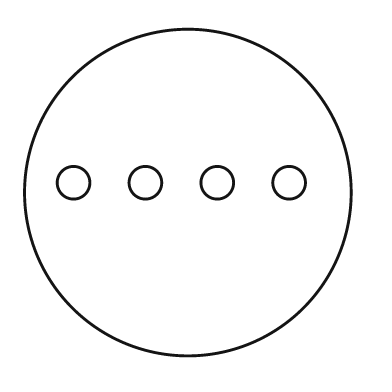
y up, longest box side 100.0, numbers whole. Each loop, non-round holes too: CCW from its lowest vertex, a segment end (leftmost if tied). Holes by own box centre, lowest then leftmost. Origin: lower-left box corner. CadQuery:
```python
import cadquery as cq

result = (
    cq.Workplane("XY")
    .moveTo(50.0, 50.0)
    .circle(50.0)
    .moveTo(15.0, 53.0)
    .circle(5.0)
    .moveTo(37.0, 53.0)
    .circle(5.0)
    .moveTo(59.0, 53.0)
    .circle(5.0)
    .moveTo(81.0, 53.0)
    .circle(5.0)
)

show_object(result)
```